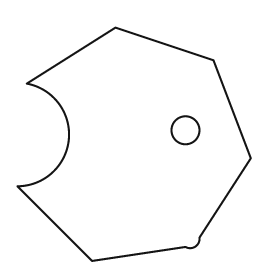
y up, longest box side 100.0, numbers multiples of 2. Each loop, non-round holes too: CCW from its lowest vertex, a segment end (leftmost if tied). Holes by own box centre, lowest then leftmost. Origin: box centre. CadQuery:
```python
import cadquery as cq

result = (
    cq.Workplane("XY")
    .moveTo(-18.0, -50.0)
    .lineTo(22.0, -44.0)
    .threePointArc((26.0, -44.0), (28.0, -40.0))
    .lineTo(50.0, -6.0)
    .lineTo(34.0, 36.0)
    .lineTo(-8.0, 50.0)
    .lineTo(-46.0, 26.0)
    .threePointArc((-28.0, 2.0), (-50.0, -18.0))
    .close()
    .moveTo(22.0, 6.0)
    .circle(6.0)
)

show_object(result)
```